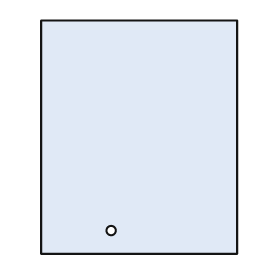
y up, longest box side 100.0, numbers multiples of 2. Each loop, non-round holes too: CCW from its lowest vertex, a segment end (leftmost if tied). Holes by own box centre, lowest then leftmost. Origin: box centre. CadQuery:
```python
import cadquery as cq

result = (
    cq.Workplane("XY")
    .moveTo(-42.0, -50.0)
    .lineTo(42.0, -50.0)
    .lineTo(42.0, 50.0)
    .lineTo(-42.0, 50.0)
    .close()
    .moveTo(-12.0, -40.0)
    .circle(2.0)
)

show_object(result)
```